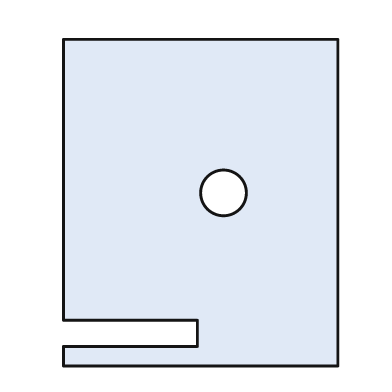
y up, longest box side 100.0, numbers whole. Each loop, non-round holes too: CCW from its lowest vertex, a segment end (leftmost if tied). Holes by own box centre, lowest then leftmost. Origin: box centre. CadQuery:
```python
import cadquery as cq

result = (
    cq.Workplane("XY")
    .moveTo(-42.0, -50.0)
    .lineTo(42.0, -50.0)
    .lineTo(42.0, 50.0)
    .lineTo(-42.0, 50.0)
    .lineTo(-42.0, -36.0)
    .lineTo(-1.0, -36.0)
    .lineTo(-1.0, -44.0)
    .lineTo(-42.0, -44.0)
    .close()
    .moveTo(7.0, 3.0)
    .circle(7.0)
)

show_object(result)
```